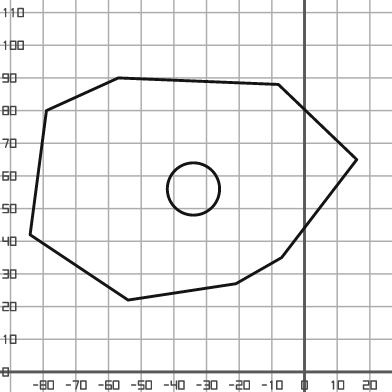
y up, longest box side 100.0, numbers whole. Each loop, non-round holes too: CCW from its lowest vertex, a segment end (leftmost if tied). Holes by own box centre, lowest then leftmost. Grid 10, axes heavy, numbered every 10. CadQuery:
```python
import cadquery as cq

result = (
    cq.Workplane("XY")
    .moveTo(-54.0, 22.0)
    .lineTo(-21.0, 27.0)
    .lineTo(-7.0, 35.0)
    .lineTo(16.0, 65.0)
    .lineTo(-8.0, 88.0)
    .lineTo(-57.0, 90.0)
    .lineTo(-79.0, 80.0)
    .lineTo(-84.0, 42.0)
    .close()
    .moveTo(-34.0, 56.0)
    .circle(8.0)
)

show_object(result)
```